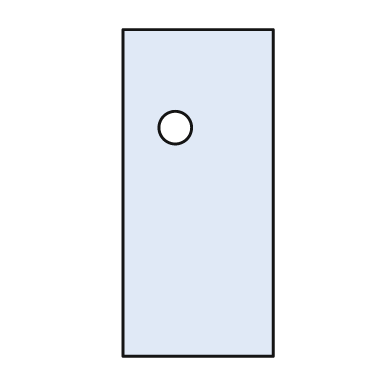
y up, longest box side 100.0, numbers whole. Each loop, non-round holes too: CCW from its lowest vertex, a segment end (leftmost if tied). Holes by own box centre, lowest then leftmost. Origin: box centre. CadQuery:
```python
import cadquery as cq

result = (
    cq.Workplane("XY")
    .moveTo(-23.0, -50.0)
    .lineTo(23.0, -50.0)
    .lineTo(23.0, 50.0)
    .lineTo(-23.0, 50.0)
    .close()
    .moveTo(-7.0, 20.0)
    .circle(5.0)
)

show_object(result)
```